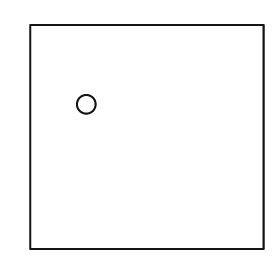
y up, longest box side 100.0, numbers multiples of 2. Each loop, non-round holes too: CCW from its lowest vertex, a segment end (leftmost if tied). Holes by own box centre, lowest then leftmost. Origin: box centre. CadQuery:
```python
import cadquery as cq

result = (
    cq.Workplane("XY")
    .moveTo(-50.0, -48.0)
    .lineTo(50.0, -48.0)
    .lineTo(50.0, 48.0)
    .lineTo(-50.0, 48.0)
    .close()
    .moveTo(-26.0, 14.0)
    .circle(4.0)
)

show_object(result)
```